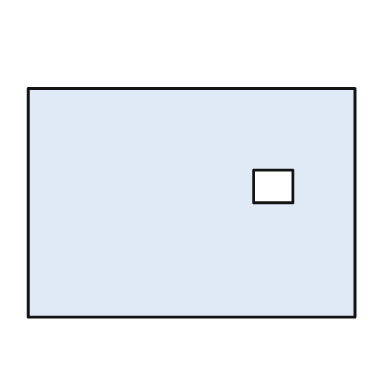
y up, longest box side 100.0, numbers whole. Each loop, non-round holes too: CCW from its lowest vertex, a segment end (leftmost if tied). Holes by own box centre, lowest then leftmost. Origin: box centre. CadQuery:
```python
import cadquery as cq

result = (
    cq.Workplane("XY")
    .moveTo(-50.0, -35.0)
    .lineTo(50.0, -35.0)
    .lineTo(50.0, 35.0)
    .lineTo(-50.0, 35.0)
    .close()
    .moveTo(19.0, 0.0)
    .lineTo(31.0, 0.0)
    .lineTo(31.0, 10.0)
    .lineTo(19.0, 10.0)
    .close()
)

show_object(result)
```